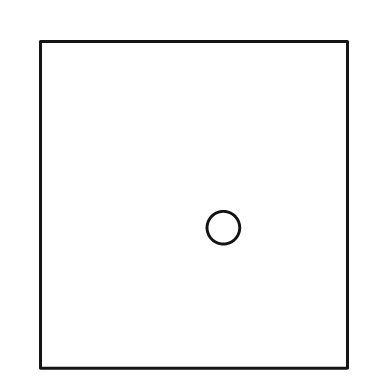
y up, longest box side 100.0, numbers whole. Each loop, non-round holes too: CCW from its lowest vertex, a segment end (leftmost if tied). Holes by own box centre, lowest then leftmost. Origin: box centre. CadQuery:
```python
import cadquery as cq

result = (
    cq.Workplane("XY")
    .moveTo(-47.0, -50.0)
    .lineTo(47.0, -50.0)
    .lineTo(47.0, 50.0)
    .lineTo(-47.0, 50.0)
    .close()
    .moveTo(9.0, -7.0)
    .circle(5.0)
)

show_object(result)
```